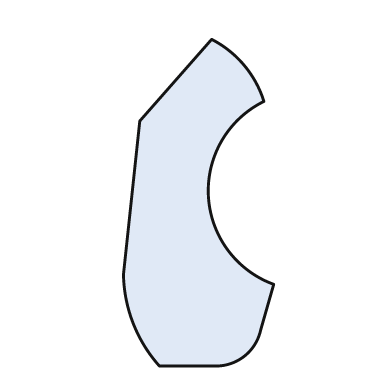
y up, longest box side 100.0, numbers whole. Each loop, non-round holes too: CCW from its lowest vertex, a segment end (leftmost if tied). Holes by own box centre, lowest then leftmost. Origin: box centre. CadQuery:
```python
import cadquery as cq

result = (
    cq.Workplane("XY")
    .moveTo(-12.0, -50.0)
    .lineTo(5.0, -50.0)
    .threePointArc((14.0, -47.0), (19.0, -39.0))
    .lineTo(23.0, -25.0)
    .threePointArc((3.0, 2.0), (20.0, 31.0))
    .threePointArc((14.0, 42.0), (4.0, 50.0))
    .lineTo(-18.0, 25.0)
    .lineTo(-23.0, -22.0)
    .threePointArc((-20.0, -37.0), (-12.0, -50.0))
    .close()
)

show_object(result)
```